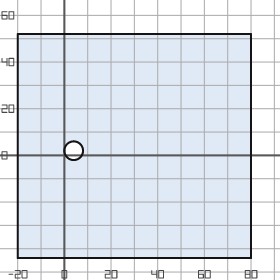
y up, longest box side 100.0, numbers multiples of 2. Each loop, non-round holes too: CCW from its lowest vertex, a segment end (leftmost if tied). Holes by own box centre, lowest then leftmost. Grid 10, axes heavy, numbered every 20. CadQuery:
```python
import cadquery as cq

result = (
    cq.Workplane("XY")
    .moveTo(-20.0, -44.0)
    .lineTo(80.0, -44.0)
    .lineTo(80.0, 52.0)
    .lineTo(-20.0, 52.0)
    .close()
    .moveTo(4.0, 2.0)
    .circle(4.0)
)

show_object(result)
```